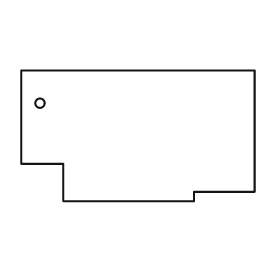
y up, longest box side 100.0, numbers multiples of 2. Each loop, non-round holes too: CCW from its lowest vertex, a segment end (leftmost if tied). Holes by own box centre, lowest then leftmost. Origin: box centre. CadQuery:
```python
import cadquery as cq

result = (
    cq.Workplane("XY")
    .moveTo(-32.0, -28.0)
    .lineTo(24.0, -28.0)
    .lineTo(24.0, -24.0)
    .lineTo(50.0, -24.0)
    .lineTo(50.0, 28.0)
    .lineTo(-50.0, 28.0)
    .lineTo(-50.0, -12.0)
    .lineTo(-32.0, -12.0)
    .close()
    .moveTo(-42.0, 14.0)
    .circle(2.0)
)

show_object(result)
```